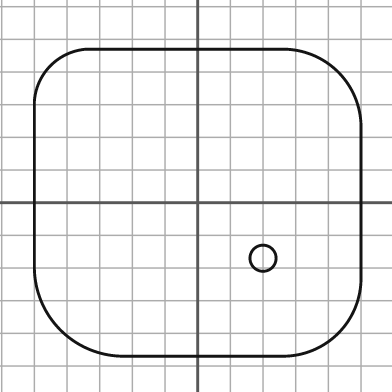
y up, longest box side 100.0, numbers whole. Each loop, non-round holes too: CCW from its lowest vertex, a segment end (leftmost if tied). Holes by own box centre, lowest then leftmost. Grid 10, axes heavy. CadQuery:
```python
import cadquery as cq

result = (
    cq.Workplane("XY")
    .moveTo(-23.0, -47.0)
    .lineTo(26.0, -47.0)
    .threePointArc((43.0, -40.0), (50.0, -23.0))
    .lineTo(50.0, 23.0)
    .threePointArc((43.0, 40.0), (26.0, 47.0))
    .lineTo(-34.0, 47.0)
    .threePointArc((-45.0, 42.0), (-50.0, 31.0))
    .lineTo(-50.0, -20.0)
    .threePointArc((-42.0, -39.0), (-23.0, -47.0))
    .close()
    .moveTo(20.0, -17.0)
    .circle(4.0)
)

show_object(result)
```